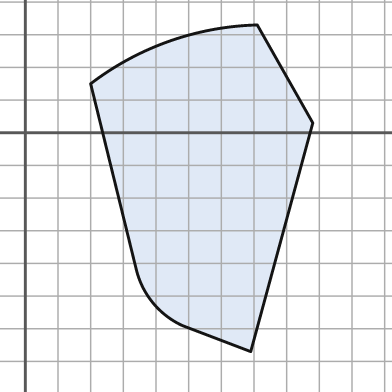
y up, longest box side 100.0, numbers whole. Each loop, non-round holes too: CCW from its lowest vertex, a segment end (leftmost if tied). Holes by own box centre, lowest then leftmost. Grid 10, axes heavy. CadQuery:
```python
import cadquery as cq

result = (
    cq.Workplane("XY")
    .moveTo(69.0, -67.0)
    .lineTo(88.0, 3.0)
    .lineTo(71.0, 33.0)
    .threePointArc((44.0, 28.0), (20.0, 15.0))
    .lineTo(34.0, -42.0)
    .threePointArc((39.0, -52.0), (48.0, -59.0))
    .close()
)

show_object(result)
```